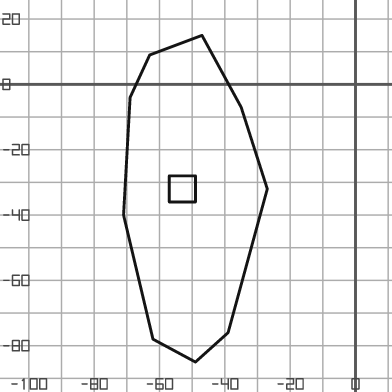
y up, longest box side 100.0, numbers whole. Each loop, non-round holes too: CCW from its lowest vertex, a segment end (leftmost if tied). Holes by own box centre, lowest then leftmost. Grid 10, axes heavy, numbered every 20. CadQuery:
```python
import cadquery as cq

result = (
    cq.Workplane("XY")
    .moveTo(-49.0, -85.0)
    .lineTo(-39.0, -76.0)
    .lineTo(-27.0, -32.0)
    .lineTo(-35.0, -7.0)
    .lineTo(-47.0, 15.0)
    .lineTo(-63.0, 9.0)
    .lineTo(-69.0, -4.0)
    .lineTo(-71.0, -40.0)
    .lineTo(-62.0, -78.0)
    .close()
    .moveTo(-57.0, -36.0)
    .lineTo(-49.0, -36.0)
    .lineTo(-49.0, -28.0)
    .lineTo(-57.0, -28.0)
    .close()
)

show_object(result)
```